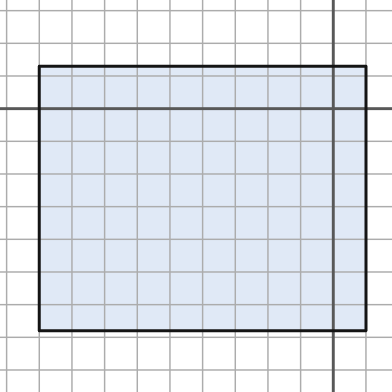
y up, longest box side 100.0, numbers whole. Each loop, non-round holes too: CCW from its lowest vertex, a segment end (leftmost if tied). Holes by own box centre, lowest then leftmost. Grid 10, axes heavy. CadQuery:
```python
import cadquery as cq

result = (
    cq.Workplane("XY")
    .moveTo(-90.0, -68.0)
    .lineTo(10.0, -68.0)
    .lineTo(10.0, 13.0)
    .lineTo(-90.0, 13.0)
    .close()
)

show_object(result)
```